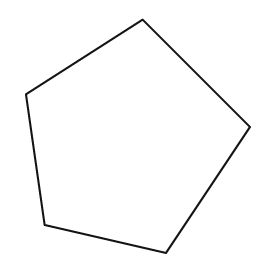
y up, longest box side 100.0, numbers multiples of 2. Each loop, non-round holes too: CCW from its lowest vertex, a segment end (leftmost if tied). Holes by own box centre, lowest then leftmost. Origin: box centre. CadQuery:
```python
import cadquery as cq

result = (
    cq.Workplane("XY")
    .moveTo(12.0, -50.0)
    .lineTo(48.0, 4.0)
    .lineTo(2.0, 50.0)
    .lineTo(-48.0, 18.0)
    .lineTo(-40.0, -38.0)
    .close()
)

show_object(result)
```